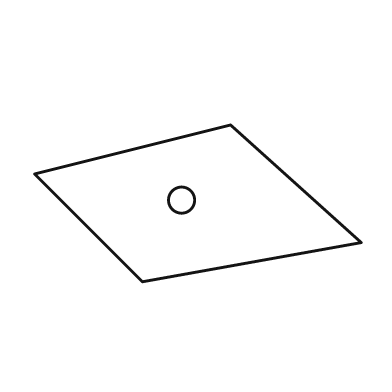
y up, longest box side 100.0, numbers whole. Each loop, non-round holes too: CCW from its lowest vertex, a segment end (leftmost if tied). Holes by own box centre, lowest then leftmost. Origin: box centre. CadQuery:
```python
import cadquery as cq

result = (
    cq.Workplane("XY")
    .moveTo(-17.0, -24.0)
    .lineTo(50.0, -12.0)
    .lineTo(10.0, 24.0)
    .lineTo(-50.0, 9.0)
    .close()
    .moveTo(-5.0, 1.0)
    .circle(4.0)
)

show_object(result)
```